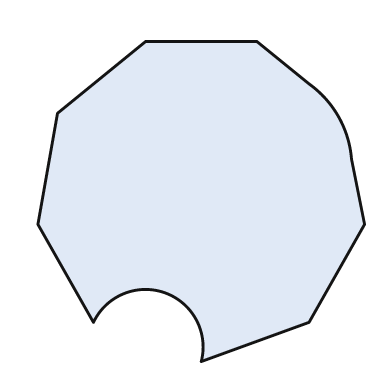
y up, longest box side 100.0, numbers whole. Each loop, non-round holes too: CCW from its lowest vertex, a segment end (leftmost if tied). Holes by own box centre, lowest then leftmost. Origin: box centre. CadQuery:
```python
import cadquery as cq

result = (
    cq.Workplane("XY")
    .moveTo(0.0, -49.0)
    .lineTo(33.0, -37.0)
    .lineTo(50.0, -7.0)
    .lineTo(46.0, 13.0)
    .threePointArc((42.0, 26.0), (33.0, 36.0))
    .lineTo(17.0, 49.0)
    .lineTo(-17.0, 49.0)
    .lineTo(-44.0, 27.0)
    .lineTo(-50.0, -7.0)
    .lineTo(-33.0, -37.0)
    .threePointArc((-11.0, -28.0), (0.0, -49.0))
    .close()
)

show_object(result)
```